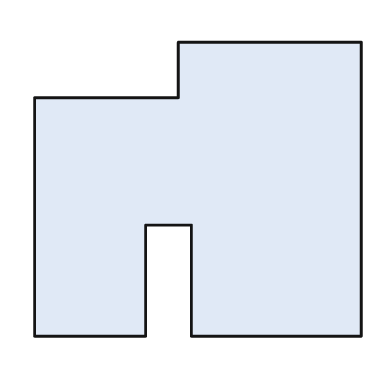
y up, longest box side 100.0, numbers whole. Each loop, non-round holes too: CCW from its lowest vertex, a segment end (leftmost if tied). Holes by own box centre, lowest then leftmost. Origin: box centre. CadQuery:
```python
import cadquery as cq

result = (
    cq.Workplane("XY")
    .moveTo(-50.0, -45.0)
    .lineTo(-16.0, -45.0)
    .lineTo(-16.0, -11.0)
    .lineTo(-2.0, -11.0)
    .lineTo(-2.0, -45.0)
    .lineTo(50.0, -45.0)
    .lineTo(50.0, 45.0)
    .lineTo(-6.0, 45.0)
    .lineTo(-6.0, 28.0)
    .lineTo(-50.0, 28.0)
    .close()
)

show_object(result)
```